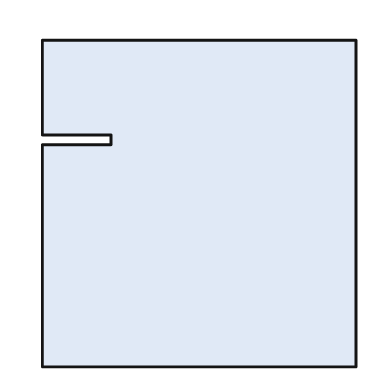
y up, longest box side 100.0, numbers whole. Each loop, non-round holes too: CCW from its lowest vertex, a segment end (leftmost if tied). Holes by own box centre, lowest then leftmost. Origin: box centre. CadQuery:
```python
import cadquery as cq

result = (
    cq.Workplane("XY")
    .moveTo(-48.0, -50.0)
    .lineTo(48.0, -50.0)
    .lineTo(48.0, 50.0)
    .lineTo(-48.0, 50.0)
    .lineTo(-48.0, 21.0)
    .lineTo(-27.0, 21.0)
    .lineTo(-27.0, 18.0)
    .lineTo(-48.0, 18.0)
    .close()
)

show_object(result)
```